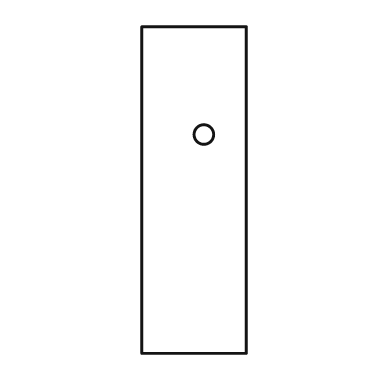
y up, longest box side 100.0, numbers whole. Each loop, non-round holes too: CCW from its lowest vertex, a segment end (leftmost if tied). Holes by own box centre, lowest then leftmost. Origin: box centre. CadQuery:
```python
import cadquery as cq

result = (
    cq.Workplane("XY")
    .moveTo(-16.0, -50.0)
    .lineTo(16.0, -50.0)
    .lineTo(16.0, 50.0)
    .lineTo(-16.0, 50.0)
    .close()
    .moveTo(3.0, 17.0)
    .circle(3.0)
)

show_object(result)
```